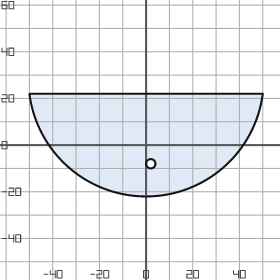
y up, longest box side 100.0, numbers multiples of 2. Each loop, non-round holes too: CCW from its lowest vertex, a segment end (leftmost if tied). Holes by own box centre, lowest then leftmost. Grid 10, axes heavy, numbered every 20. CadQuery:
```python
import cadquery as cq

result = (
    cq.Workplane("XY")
    .moveTo(-50.0, 22.0)
    .threePointArc((0.0, -22.0), (50.0, 22.0))
    .close()
    .moveTo(2.0, -8.0)
    .circle(2.0)
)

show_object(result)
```